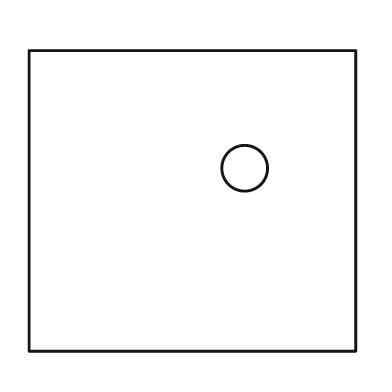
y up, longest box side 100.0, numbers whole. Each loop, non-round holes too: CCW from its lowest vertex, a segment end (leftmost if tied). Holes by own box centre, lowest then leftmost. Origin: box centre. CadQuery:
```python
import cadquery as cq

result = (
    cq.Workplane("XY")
    .moveTo(-50.0, -46.0)
    .lineTo(50.0, -46.0)
    .lineTo(50.0, 46.0)
    .lineTo(-50.0, 46.0)
    .close()
    .moveTo(16.0, 10.0)
    .circle(7.0)
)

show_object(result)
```